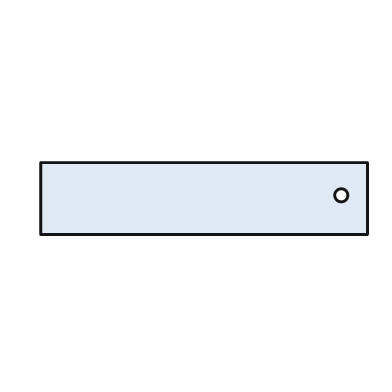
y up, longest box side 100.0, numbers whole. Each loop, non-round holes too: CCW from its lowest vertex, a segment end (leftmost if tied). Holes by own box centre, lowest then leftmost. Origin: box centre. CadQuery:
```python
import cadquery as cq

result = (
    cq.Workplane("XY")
    .moveTo(-50.0, -11.0)
    .lineTo(50.0, -11.0)
    .lineTo(50.0, 11.0)
    .lineTo(-50.0, 11.0)
    .close()
    .moveTo(42.0, 1.0)
    .circle(2.0)
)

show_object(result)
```